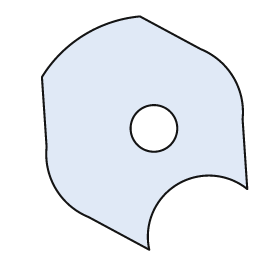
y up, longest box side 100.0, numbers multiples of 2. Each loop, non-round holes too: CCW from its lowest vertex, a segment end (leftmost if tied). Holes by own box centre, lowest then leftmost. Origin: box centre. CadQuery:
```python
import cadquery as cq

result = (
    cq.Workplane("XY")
    .moveTo(2.0, -50.0)
    .threePointArc((14.0, -22.0), (44.0, -24.0))
    .lineTo(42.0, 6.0)
    .threePointArc((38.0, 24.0), (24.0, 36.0))
    .lineTo(-2.0, 50.0)
    .threePointArc((-26.0, 42.0), (-44.0, 24.0))
    .lineTo(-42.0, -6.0)
    .threePointArc((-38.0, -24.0), (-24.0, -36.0))
    .close()
    .moveTo(4.0, 2.0)
    .circle(10.0)
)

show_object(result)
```